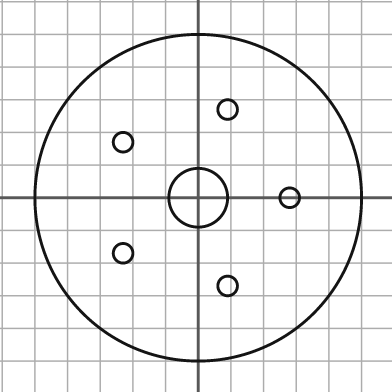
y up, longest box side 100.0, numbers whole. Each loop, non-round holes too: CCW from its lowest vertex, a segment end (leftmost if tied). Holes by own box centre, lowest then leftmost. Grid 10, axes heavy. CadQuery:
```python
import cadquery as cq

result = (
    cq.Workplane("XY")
    .moveTo(0.0, 0.0)
    .circle(50.0)
    .moveTo(9.0, -27.0)
    .circle(3.0)
    .moveTo(-23.0, -17.0)
    .circle(3.0)
    .moveTo(0.0, 0.0)
    .circle(9.0)
    .moveTo(28.0, 0.0)
    .circle(3.0)
    .moveTo(-23.0, 17.0)
    .circle(3.0)
    .moveTo(9.0, 27.0)
    .circle(3.0)
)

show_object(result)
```